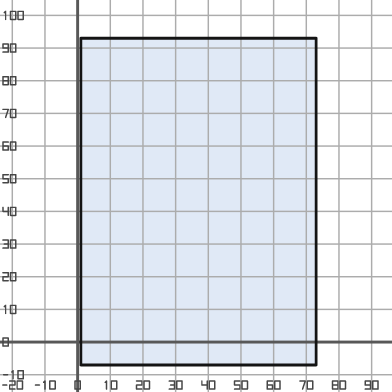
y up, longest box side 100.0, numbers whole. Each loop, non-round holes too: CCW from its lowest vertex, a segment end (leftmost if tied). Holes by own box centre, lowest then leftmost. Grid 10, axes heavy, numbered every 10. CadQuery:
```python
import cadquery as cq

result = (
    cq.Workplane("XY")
    .moveTo(1.0, -7.0)
    .lineTo(73.0, -7.0)
    .lineTo(73.0, 93.0)
    .lineTo(1.0, 93.0)
    .close()
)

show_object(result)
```